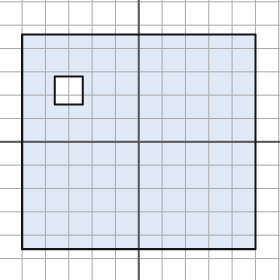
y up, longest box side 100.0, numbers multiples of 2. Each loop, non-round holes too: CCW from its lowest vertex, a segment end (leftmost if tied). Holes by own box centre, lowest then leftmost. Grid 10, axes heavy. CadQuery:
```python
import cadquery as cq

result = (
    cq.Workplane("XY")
    .moveTo(-50.0, -46.0)
    .lineTo(50.0, -46.0)
    .lineTo(50.0, 46.0)
    .lineTo(-50.0, 46.0)
    .close()
    .moveTo(-36.0, 16.0)
    .lineTo(-24.0, 16.0)
    .lineTo(-24.0, 28.0)
    .lineTo(-36.0, 28.0)
    .close()
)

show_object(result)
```